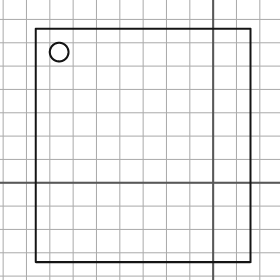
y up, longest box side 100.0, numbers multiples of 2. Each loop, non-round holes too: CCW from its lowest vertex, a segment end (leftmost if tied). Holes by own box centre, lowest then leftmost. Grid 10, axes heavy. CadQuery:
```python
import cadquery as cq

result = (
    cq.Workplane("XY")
    .moveTo(-76.0, -34.0)
    .lineTo(16.0, -34.0)
    .lineTo(16.0, 66.0)
    .lineTo(-76.0, 66.0)
    .close()
    .moveTo(-66.0, 56.0)
    .circle(4.0)
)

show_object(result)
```